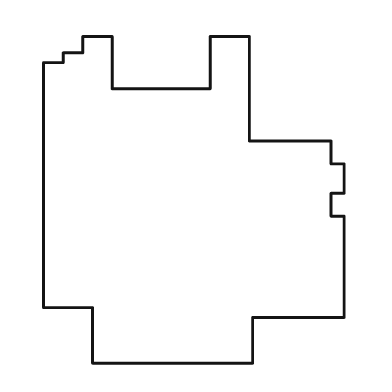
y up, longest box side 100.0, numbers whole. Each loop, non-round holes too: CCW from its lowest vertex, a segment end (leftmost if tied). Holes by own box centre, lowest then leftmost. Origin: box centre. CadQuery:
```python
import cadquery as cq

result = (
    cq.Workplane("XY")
    .moveTo(-31.0, -50.0)
    .lineTo(18.0, -50.0)
    .lineTo(18.0, -36.0)
    .lineTo(46.0, -36.0)
    .lineTo(46.0, -5.0)
    .lineTo(42.0, -5.0)
    .lineTo(42.0, 2.0)
    .lineTo(46.0, 2.0)
    .lineTo(46.0, 11.0)
    .lineTo(42.0, 11.0)
    .lineTo(42.0, 18.0)
    .lineTo(17.0, 18.0)
    .lineTo(17.0, 50.0)
    .lineTo(5.0, 50.0)
    .lineTo(5.0, 34.0)
    .lineTo(-25.0, 34.0)
    .lineTo(-25.0, 50.0)
    .lineTo(-34.0, 50.0)
    .lineTo(-34.0, 45.0)
    .lineTo(-40.0, 45.0)
    .lineTo(-40.0, 42.0)
    .lineTo(-46.0, 42.0)
    .lineTo(-46.0, -33.0)
    .lineTo(-31.0, -33.0)
    .close()
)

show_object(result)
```